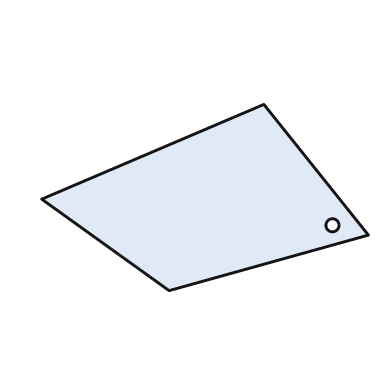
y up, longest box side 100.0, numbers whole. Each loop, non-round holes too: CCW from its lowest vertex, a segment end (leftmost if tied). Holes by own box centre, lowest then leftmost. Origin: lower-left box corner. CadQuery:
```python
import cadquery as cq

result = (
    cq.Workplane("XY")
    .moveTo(39.0, 0.0)
    .lineTo(100.0, 17.0)
    .lineTo(68.0, 57.0)
    .lineTo(0.0, 28.0)
    .close()
    .moveTo(89.0, 20.0)
    .circle(2.0)
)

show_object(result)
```